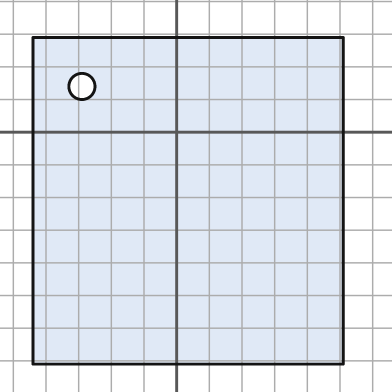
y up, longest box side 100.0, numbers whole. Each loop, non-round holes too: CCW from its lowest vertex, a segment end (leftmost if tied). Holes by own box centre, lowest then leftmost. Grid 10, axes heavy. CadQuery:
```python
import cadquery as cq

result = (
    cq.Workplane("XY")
    .moveTo(-44.0, -71.0)
    .lineTo(51.0, -71.0)
    .lineTo(51.0, 29.0)
    .lineTo(-44.0, 29.0)
    .close()
    .moveTo(-29.0, 14.0)
    .circle(4.0)
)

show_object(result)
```